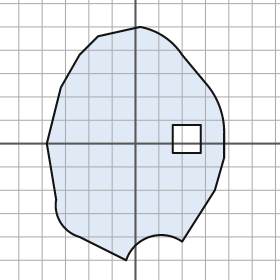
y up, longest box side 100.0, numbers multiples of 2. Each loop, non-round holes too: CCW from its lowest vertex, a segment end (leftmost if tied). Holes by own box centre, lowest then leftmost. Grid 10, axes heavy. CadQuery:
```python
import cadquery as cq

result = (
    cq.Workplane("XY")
    .moveTo(-4.0, -50.0)
    .threePointArc((6.0, -40.0), (20.0, -42.0))
    .lineTo(34.0, -20.0)
    .lineTo(38.0, -6.0)
    .lineTo(38.0, 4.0)
    .threePointArc((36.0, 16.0), (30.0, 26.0))
    .lineTo(20.0, 38.0)
    .threePointArc((12.0, 46.0), (2.0, 50.0))
    .lineTo(-16.0, 46.0)
    .lineTo(-24.0, 38.0)
    .lineTo(-32.0, 24.0)
    .lineTo(-38.0, 0.0)
    .lineTo(-34.0, -24.0)
    .threePointArc((-32.0, -34.0), (-24.0, -40.0))
    .close()
    .moveTo(16.0, -4.0)
    .lineTo(28.0, -4.0)
    .lineTo(28.0, 8.0)
    .lineTo(16.0, 8.0)
    .close()
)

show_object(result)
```